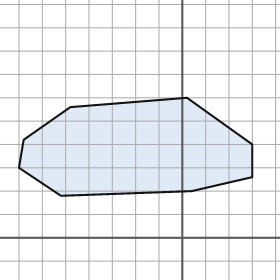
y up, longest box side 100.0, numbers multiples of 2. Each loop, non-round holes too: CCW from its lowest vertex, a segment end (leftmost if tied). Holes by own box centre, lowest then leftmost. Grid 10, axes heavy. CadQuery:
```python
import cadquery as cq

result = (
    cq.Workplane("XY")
    .moveTo(-52.0, 18.0)
    .lineTo(4.0, 20.0)
    .lineTo(30.0, 26.0)
    .lineTo(30.0, 40.0)
    .lineTo(2.0, 60.0)
    .lineTo(-48.0, 56.0)
    .lineTo(-68.0, 42.0)
    .lineTo(-70.0, 30.0)
    .close()
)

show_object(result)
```